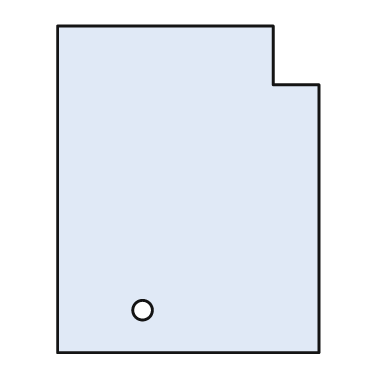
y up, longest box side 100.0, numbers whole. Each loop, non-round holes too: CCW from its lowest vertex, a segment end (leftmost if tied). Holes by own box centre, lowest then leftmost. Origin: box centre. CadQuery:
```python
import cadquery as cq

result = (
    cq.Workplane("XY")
    .moveTo(-40.0, -50.0)
    .lineTo(40.0, -50.0)
    .lineTo(40.0, 32.0)
    .lineTo(26.0, 32.0)
    .lineTo(26.0, 50.0)
    .lineTo(-40.0, 50.0)
    .close()
    .moveTo(-14.0, -37.0)
    .circle(3.0)
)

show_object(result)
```